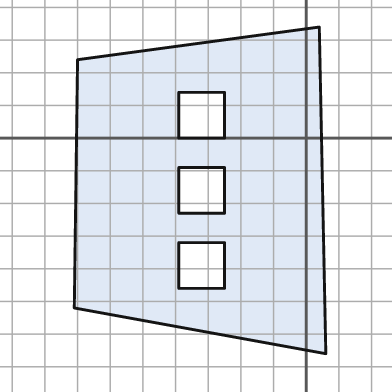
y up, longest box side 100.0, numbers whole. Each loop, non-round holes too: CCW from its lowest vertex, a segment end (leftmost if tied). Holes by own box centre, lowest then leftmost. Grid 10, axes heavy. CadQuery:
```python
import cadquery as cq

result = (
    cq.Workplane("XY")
    .moveTo(6.0, -66.0)
    .lineTo(4.0, 34.0)
    .lineTo(-70.0, 24.0)
    .lineTo(-71.0, -52.0)
    .close()
    .moveTo(-39.0, -46.0)
    .lineTo(-25.0, -46.0)
    .lineTo(-25.0, -32.0)
    .lineTo(-39.0, -32.0)
    .close()
    .moveTo(-39.0, -23.0)
    .lineTo(-25.0, -23.0)
    .lineTo(-25.0, -9.0)
    .lineTo(-39.0, -9.0)
    .close()
    .moveTo(-39.0, 0.0)
    .lineTo(-25.0, 0.0)
    .lineTo(-25.0, 14.0)
    .lineTo(-39.0, 14.0)
    .close()
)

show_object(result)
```